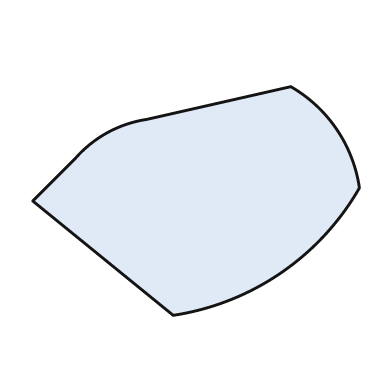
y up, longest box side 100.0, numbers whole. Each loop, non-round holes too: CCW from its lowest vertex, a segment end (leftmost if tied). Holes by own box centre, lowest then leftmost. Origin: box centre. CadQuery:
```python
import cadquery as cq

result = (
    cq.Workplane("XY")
    .moveTo(-7.0, -35.0)
    .threePointArc((26.0, -22.0), (50.0, 4.0))
    .threePointArc((43.0, 22.0), (29.0, 35.0))
    .lineTo(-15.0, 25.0)
    .threePointArc((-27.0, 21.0), (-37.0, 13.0))
    .lineTo(-50.0, 0.0)
    .close()
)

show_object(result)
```